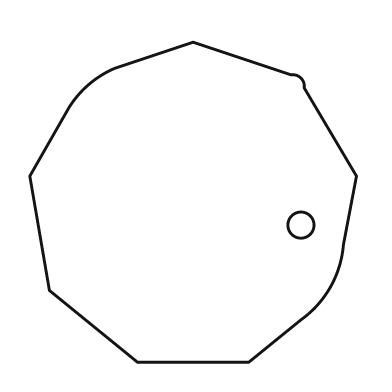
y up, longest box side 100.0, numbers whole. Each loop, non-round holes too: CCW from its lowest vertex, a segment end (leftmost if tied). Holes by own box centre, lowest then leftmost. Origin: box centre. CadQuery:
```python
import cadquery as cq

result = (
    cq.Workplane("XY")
    .moveTo(-17.0, -49.0)
    .lineTo(17.0, -49.0)
    .lineTo(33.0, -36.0)
    .threePointArc((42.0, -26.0), (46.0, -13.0))
    .lineTo(50.0, 8.0)
    .lineTo(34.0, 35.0)
    .threePointArc((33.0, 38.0), (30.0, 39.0))
    .lineTo(0.0, 49.0)
    .lineTo(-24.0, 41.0)
    .threePointArc((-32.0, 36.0), (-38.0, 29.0))
    .lineTo(-50.0, 8.0)
    .lineTo(-44.0, -27.0)
    .close()
    .moveTo(33.0, -7.0)
    .circle(4.0)
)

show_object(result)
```